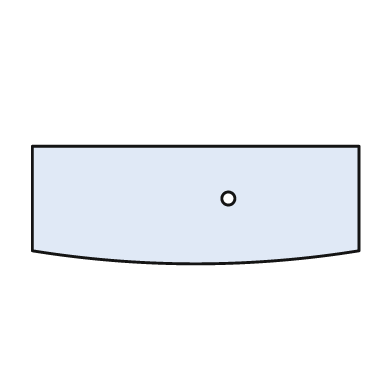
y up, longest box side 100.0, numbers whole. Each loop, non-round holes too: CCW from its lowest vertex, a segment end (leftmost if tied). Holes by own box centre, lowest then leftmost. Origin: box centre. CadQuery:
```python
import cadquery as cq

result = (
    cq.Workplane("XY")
    .moveTo(-50.0, -14.0)
    .threePointArc((0.0, -18.0), (50.0, -14.0))
    .lineTo(50.0, 18.0)
    .lineTo(-50.0, 18.0)
    .close()
    .moveTo(10.0, 2.0)
    .circle(2.0)
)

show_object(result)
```